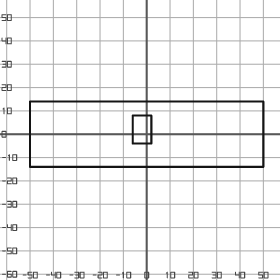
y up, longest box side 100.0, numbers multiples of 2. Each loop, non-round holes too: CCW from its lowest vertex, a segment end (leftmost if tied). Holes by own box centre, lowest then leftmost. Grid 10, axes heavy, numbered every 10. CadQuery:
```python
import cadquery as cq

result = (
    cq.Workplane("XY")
    .moveTo(-50.0, -14.0)
    .lineTo(50.0, -14.0)
    .lineTo(50.0, 14.0)
    .lineTo(-50.0, 14.0)
    .close()
    .moveTo(-6.0, -4.0)
    .lineTo(2.0, -4.0)
    .lineTo(2.0, 8.0)
    .lineTo(-6.0, 8.0)
    .close()
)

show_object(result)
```